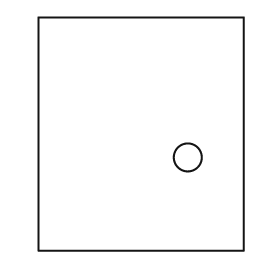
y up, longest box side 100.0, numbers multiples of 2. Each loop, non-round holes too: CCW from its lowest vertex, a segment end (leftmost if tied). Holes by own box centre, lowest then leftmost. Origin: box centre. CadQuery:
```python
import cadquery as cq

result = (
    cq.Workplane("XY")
    .moveTo(-44.0, -50.0)
    .lineTo(44.0, -50.0)
    .lineTo(44.0, 50.0)
    .lineTo(-44.0, 50.0)
    .close()
    .moveTo(20.0, -10.0)
    .circle(6.0)
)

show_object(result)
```